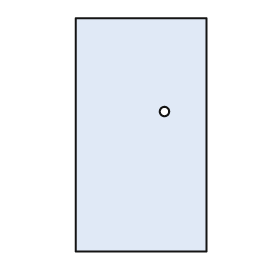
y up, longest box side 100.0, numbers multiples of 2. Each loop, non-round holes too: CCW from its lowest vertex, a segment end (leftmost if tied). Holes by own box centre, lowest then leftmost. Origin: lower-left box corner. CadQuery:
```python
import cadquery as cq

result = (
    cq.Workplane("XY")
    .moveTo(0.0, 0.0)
    .lineTo(56.0, 0.0)
    .lineTo(56.0, 100.0)
    .lineTo(0.0, 100.0)
    .close()
    .moveTo(38.0, 60.0)
    .circle(2.0)
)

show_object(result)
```